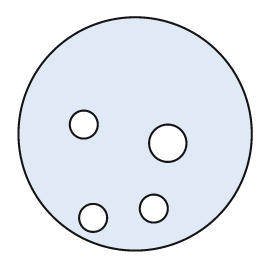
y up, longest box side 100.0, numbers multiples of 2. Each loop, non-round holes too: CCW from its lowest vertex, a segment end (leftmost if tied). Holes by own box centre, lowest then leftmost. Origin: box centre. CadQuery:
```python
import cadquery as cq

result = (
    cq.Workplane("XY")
    .moveTo(0.0, 0.0)
    .circle(50.0)
    .moveTo(-18.0, -36.0)
    .circle(6.0)
    .moveTo(8.0, -32.0)
    .circle(6.0)
    .moveTo(14.0, -4.0)
    .circle(8.0)
    .moveTo(-22.0, 4.0)
    .circle(6.0)
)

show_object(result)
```